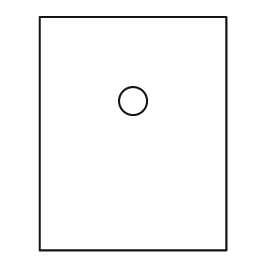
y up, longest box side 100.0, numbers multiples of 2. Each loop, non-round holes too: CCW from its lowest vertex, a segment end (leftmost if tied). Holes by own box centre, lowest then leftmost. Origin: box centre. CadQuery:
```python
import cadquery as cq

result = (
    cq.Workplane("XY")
    .moveTo(-40.0, -50.0)
    .lineTo(40.0, -50.0)
    .lineTo(40.0, 50.0)
    .lineTo(-40.0, 50.0)
    .close()
    .moveTo(0.0, 14.0)
    .circle(6.0)
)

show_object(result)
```